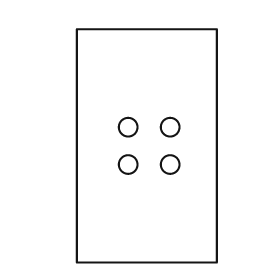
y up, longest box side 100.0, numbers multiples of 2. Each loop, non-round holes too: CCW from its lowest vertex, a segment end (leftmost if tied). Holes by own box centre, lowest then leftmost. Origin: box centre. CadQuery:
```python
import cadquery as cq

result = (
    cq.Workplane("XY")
    .moveTo(-30.0, -50.0)
    .lineTo(30.0, -50.0)
    .lineTo(30.0, 50.0)
    .lineTo(-30.0, 50.0)
    .close()
    .moveTo(-8.0, -8.0)
    .circle(4.0)
    .moveTo(10.0, -8.0)
    .circle(4.0)
    .moveTo(-8.0, 8.0)
    .circle(4.0)
    .moveTo(10.0, 8.0)
    .circle(4.0)
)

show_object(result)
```